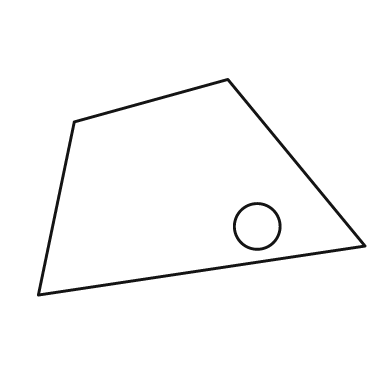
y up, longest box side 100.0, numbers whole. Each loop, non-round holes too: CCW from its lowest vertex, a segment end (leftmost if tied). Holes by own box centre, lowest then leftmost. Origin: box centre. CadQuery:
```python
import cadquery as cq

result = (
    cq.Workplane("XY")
    .moveTo(-50.0, -33.0)
    .lineTo(50.0, -18.0)
    .lineTo(8.0, 33.0)
    .lineTo(-39.0, 20.0)
    .close()
    .moveTo(17.0, -12.0)
    .circle(7.0)
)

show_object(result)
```